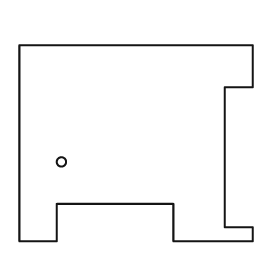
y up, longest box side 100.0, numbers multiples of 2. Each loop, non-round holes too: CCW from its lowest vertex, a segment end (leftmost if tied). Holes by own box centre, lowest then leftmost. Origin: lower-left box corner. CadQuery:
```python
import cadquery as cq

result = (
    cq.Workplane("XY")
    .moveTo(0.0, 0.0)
    .lineTo(16.0, 0.0)
    .lineTo(16.0, 16.0)
    .lineTo(66.0, 16.0)
    .lineTo(66.0, 0.0)
    .lineTo(100.0, 0.0)
    .lineTo(100.0, 6.0)
    .lineTo(88.0, 6.0)
    .lineTo(88.0, 66.0)
    .lineTo(100.0, 66.0)
    .lineTo(100.0, 84.0)
    .lineTo(0.0, 84.0)
    .close()
    .moveTo(18.0, 34.0)
    .circle(2.0)
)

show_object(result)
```